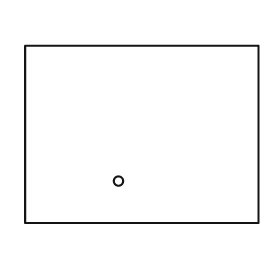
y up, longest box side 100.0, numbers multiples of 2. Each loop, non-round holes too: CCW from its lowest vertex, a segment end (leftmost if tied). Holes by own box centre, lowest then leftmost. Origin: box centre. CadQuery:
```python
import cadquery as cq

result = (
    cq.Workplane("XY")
    .moveTo(-50.0, -38.0)
    .lineTo(50.0, -38.0)
    .lineTo(50.0, 38.0)
    .lineTo(-50.0, 38.0)
    .close()
    .moveTo(-10.0, -20.0)
    .circle(2.0)
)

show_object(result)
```